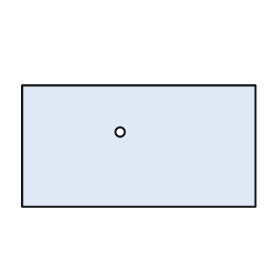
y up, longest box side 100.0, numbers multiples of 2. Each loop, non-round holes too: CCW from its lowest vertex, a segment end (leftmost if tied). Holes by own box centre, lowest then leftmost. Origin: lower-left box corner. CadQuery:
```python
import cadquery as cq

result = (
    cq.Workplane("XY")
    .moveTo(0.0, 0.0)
    .lineTo(100.0, 0.0)
    .lineTo(100.0, 52.0)
    .lineTo(0.0, 52.0)
    .close()
    .moveTo(42.0, 32.0)
    .circle(2.0)
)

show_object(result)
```